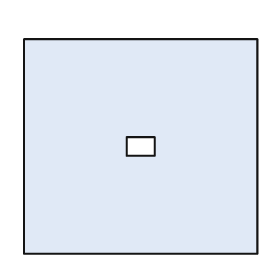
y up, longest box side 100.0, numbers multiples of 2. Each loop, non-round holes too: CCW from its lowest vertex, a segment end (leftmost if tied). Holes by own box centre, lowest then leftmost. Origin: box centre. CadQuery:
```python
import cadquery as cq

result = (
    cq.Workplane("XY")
    .moveTo(-50.0, -46.0)
    .lineTo(50.0, -46.0)
    .lineTo(50.0, 46.0)
    .lineTo(-50.0, 46.0)
    .close()
    .moveTo(-6.0, -4.0)
    .lineTo(6.0, -4.0)
    .lineTo(6.0, 4.0)
    .lineTo(-6.0, 4.0)
    .close()
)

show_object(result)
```